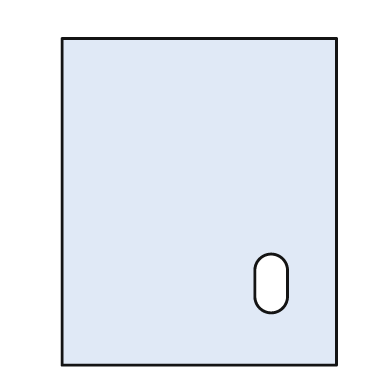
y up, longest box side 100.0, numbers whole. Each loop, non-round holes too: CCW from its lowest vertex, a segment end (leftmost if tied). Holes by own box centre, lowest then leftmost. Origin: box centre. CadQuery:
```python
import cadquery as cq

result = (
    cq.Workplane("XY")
    .moveTo(-42.0, -50.0)
    .lineTo(42.0, -50.0)
    .lineTo(42.0, 50.0)
    .lineTo(-42.0, 50.0)
    .close()
    .moveTo(17.0, -29.0)
    .threePointArc((22.0, -34.0), (27.0, -29.0))
    .lineTo(27.0, -21.0)
    .threePointArc((22.0, -16.0), (17.0, -21.0))
    .close()
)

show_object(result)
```